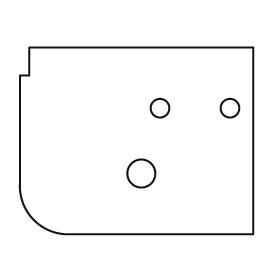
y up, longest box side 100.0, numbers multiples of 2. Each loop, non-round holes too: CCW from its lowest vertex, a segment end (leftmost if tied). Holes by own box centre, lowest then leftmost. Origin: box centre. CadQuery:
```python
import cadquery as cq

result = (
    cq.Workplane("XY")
    .moveTo(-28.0, -40.0)
    .lineTo(50.0, -40.0)
    .lineTo(50.0, 40.0)
    .lineTo(-46.0, 40.0)
    .lineTo(-46.0, 28.0)
    .lineTo(-50.0, 28.0)
    .lineTo(-50.0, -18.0)
    .threePointArc((-44.0, -34.0), (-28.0, -40.0))
    .close()
    .moveTo(2.0, -14.0)
    .circle(6.0)
    .moveTo(10.0, 14.0)
    .circle(4.0)
    .moveTo(40.0, 14.0)
    .circle(4.0)
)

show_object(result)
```